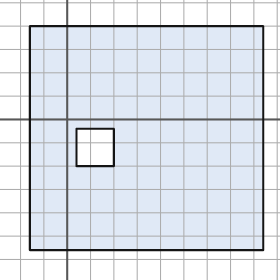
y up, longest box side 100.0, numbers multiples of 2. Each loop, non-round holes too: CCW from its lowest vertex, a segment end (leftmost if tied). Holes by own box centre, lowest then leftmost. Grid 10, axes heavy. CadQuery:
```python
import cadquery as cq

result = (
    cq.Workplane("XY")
    .moveTo(-16.0, -56.0)
    .lineTo(84.0, -56.0)
    .lineTo(84.0, 40.0)
    .lineTo(-16.0, 40.0)
    .close()
    .moveTo(4.0, -20.0)
    .lineTo(20.0, -20.0)
    .lineTo(20.0, -4.0)
    .lineTo(4.0, -4.0)
    .close()
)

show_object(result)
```